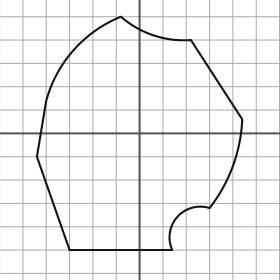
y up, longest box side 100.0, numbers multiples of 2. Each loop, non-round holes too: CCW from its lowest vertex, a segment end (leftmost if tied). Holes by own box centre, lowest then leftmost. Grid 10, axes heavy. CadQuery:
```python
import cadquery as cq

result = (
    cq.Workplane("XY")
    .moveTo(-30.0, -50.0)
    .lineTo(14.0, -50.0)
    .threePointArc((16.0, -36.0), (30.0, -32.0))
    .threePointArc((40.0, -14.0), (44.0, 6.0))
    .lineTo(22.0, 40.0)
    .threePointArc((6.0, 42.0), (-8.0, 50.0))
    .threePointArc((-28.0, 36.0), (-40.0, 14.0))
    .lineTo(-44.0, -10.0)
    .close()
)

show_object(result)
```